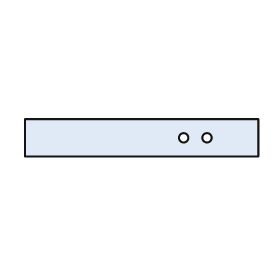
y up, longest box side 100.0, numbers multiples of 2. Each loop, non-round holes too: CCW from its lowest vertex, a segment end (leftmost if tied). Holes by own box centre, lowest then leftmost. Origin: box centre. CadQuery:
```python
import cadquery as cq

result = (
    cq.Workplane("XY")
    .moveTo(-50.0, -8.0)
    .lineTo(50.0, -8.0)
    .lineTo(50.0, 8.0)
    .lineTo(-50.0, 8.0)
    .close()
    .moveTo(18.0, 0.0)
    .circle(2.0)
    .moveTo(28.0, 0.0)
    .circle(2.0)
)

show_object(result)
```